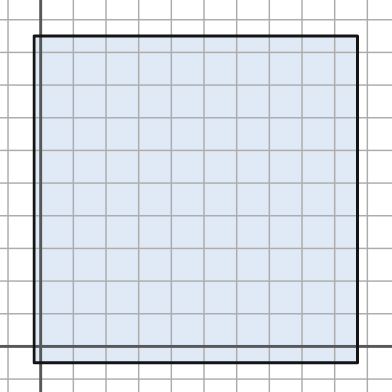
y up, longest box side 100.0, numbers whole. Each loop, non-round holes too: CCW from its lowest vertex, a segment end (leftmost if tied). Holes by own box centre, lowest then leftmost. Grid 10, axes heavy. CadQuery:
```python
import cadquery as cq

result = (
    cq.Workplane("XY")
    .moveTo(-2.0, -5.0)
    .lineTo(97.0, -5.0)
    .lineTo(97.0, 95.0)
    .lineTo(-2.0, 95.0)
    .close()
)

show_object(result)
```